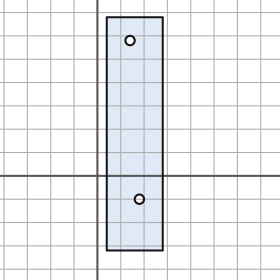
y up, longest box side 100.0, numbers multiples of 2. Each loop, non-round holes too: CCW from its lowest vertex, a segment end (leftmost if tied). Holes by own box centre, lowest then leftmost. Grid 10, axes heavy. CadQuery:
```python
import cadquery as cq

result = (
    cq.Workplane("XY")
    .moveTo(4.0, -32.0)
    .lineTo(28.0, -32.0)
    .lineTo(28.0, 68.0)
    .lineTo(4.0, 68.0)
    .close()
    .moveTo(18.0, -10.0)
    .circle(2.0)
    .moveTo(14.0, 58.0)
    .circle(2.0)
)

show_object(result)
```